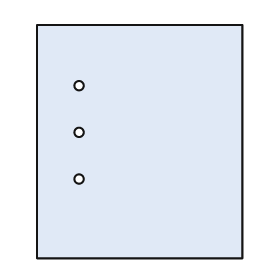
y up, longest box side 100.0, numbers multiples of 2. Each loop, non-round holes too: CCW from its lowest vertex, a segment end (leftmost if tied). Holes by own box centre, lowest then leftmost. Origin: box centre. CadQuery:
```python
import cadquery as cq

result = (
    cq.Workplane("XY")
    .moveTo(-44.0, -50.0)
    .lineTo(44.0, -50.0)
    .lineTo(44.0, 50.0)
    .lineTo(-44.0, 50.0)
    .close()
    .moveTo(-26.0, -16.0)
    .circle(2.0)
    .moveTo(-26.0, 4.0)
    .circle(2.0)
    .moveTo(-26.0, 24.0)
    .circle(2.0)
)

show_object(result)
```